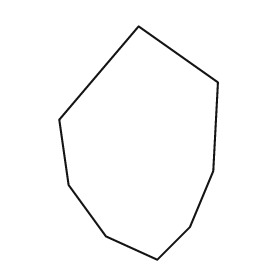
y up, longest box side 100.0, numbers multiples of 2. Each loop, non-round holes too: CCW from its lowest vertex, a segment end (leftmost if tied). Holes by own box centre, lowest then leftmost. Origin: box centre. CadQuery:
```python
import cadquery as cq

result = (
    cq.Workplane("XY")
    .moveTo(8.0, -50.0)
    .lineTo(22.0, -36.0)
    .lineTo(32.0, -12.0)
    .lineTo(34.0, 26.0)
    .lineTo(0.0, 50.0)
    .lineTo(-34.0, 10.0)
    .lineTo(-30.0, -18.0)
    .lineTo(-14.0, -40.0)
    .close()
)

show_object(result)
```